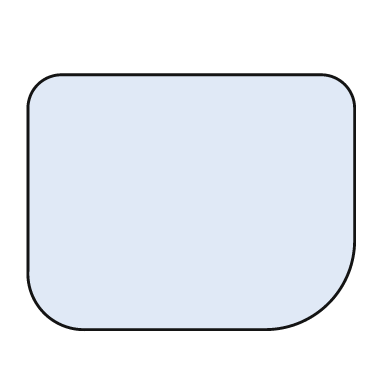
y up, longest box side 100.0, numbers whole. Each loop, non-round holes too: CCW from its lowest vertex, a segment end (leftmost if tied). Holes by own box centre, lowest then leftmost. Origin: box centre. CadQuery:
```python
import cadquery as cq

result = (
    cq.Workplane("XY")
    .moveTo(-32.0, -39.0)
    .lineTo(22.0, -39.0)
    .threePointArc((42.0, -31.0), (50.0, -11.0))
    .lineTo(50.0, 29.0)
    .threePointArc((47.0, 36.0), (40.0, 39.0))
    .lineTo(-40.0, 39.0)
    .threePointArc((-47.0, 36.0), (-50.0, 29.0))
    .lineTo(-50.0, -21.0)
    .threePointArc((-45.0, -34.0), (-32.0, -39.0))
    .close()
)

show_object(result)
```